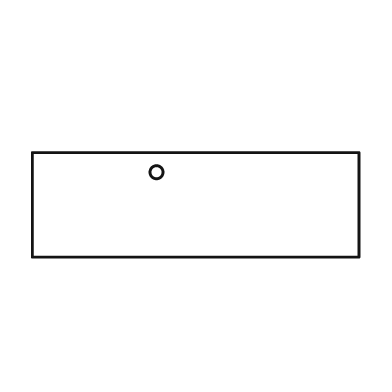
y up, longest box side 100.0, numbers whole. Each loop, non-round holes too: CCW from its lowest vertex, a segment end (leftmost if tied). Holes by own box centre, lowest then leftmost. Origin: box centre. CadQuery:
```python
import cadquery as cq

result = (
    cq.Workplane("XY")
    .moveTo(-50.0, -16.0)
    .lineTo(50.0, -16.0)
    .lineTo(50.0, 16.0)
    .lineTo(-50.0, 16.0)
    .close()
    .moveTo(-12.0, 10.0)
    .circle(2.0)
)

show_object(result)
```